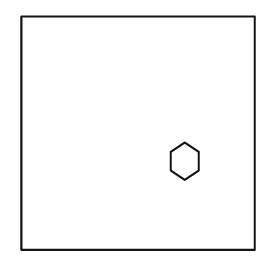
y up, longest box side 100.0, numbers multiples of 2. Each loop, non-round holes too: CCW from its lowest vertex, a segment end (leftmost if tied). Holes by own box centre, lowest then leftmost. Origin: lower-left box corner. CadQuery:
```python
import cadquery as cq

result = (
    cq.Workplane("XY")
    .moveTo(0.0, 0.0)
    .lineTo(100.0, 0.0)
    .lineTo(100.0, 100.0)
    .lineTo(0.0, 100.0)
    .close()
    .moveTo(70.0, 30.0)
    .lineTo(76.0, 34.0)
    .lineTo(76.0, 42.0)
    .lineTo(70.0, 46.0)
    .lineTo(64.0, 42.0)
    .lineTo(64.0, 34.0)
    .close()
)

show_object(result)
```